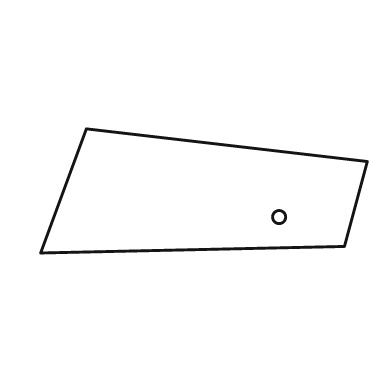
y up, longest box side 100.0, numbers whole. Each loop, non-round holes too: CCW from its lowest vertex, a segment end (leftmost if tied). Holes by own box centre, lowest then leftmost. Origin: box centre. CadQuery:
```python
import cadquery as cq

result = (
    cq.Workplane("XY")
    .moveTo(-50.0, -19.0)
    .lineTo(43.0, -17.0)
    .lineTo(50.0, 9.0)
    .lineTo(-36.0, 19.0)
    .close()
    .moveTo(23.0, -8.0)
    .circle(2.0)
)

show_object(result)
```